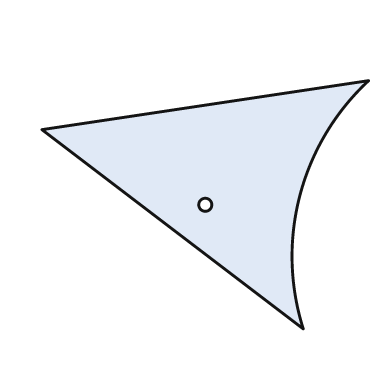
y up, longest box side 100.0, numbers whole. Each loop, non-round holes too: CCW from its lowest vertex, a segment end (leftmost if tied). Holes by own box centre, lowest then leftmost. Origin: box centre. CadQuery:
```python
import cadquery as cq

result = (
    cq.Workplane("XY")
    .moveTo(30.0, -38.0)
    .threePointArc((29.0, 3.0), (50.0, 38.0))
    .lineTo(-50.0, 23.0)
    .close()
    .moveTo(0.0, 0.0)
    .circle(2.0)
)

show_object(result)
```